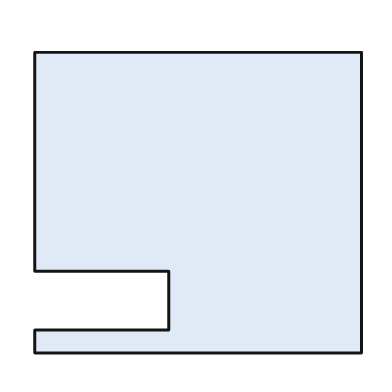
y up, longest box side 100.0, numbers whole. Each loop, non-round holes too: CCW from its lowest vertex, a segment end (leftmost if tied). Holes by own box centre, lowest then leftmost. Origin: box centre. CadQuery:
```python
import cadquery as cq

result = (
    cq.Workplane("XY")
    .moveTo(-50.0, -46.0)
    .lineTo(50.0, -46.0)
    .lineTo(50.0, 46.0)
    .lineTo(-50.0, 46.0)
    .lineTo(-50.0, -21.0)
    .lineTo(-9.0, -21.0)
    .lineTo(-9.0, -39.0)
    .lineTo(-50.0, -39.0)
    .close()
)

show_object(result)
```